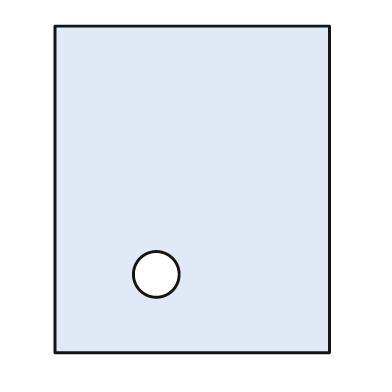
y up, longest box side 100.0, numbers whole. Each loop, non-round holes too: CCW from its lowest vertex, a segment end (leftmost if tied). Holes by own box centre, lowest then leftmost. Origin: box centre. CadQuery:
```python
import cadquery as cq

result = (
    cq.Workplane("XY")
    .moveTo(-42.0, -50.0)
    .lineTo(42.0, -50.0)
    .lineTo(42.0, 50.0)
    .lineTo(-42.0, 50.0)
    .close()
    .moveTo(-11.0, -26.0)
    .circle(7.0)
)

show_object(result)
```